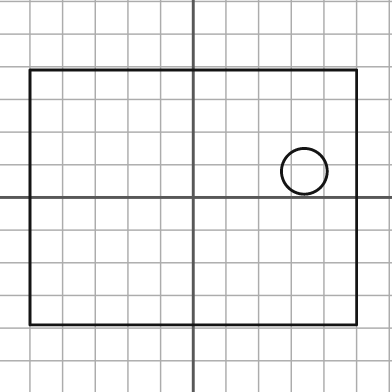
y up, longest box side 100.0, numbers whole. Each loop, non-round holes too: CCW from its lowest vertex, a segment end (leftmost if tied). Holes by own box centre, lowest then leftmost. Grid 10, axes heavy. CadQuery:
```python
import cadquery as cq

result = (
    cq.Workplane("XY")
    .moveTo(-50.0, -39.0)
    .lineTo(50.0, -39.0)
    .lineTo(50.0, 39.0)
    .lineTo(-50.0, 39.0)
    .close()
    .moveTo(34.0, 8.0)
    .circle(7.0)
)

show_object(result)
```